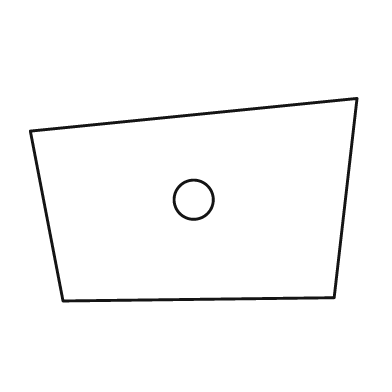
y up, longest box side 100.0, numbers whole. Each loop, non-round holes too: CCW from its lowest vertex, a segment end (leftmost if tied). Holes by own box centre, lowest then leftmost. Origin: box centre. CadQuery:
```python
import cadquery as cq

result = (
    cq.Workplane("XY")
    .moveTo(-40.0, -31.0)
    .lineTo(43.0, -30.0)
    .lineTo(50.0, 31.0)
    .lineTo(-50.0, 21.0)
    .close()
    .moveTo(0.0, 0.0)
    .circle(6.0)
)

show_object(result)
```